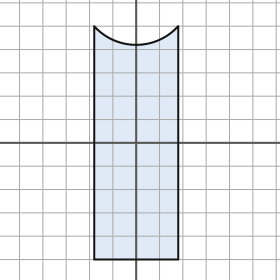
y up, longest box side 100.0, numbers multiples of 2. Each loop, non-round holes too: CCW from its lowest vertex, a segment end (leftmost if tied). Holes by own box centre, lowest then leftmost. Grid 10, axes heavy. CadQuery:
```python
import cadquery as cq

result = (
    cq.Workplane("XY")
    .moveTo(-18.0, -50.0)
    .lineTo(18.0, -50.0)
    .lineTo(18.0, 50.0)
    .threePointArc((0.0, 42.0), (-18.0, 50.0))
    .close()
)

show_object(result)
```